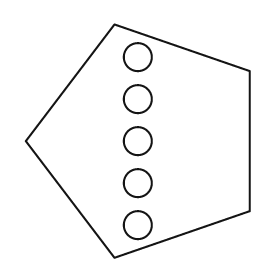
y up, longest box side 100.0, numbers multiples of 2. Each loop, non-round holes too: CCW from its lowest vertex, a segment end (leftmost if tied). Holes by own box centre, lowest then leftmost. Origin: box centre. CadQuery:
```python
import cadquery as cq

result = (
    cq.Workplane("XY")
    .moveTo(-10.0, -50.0)
    .lineTo(48.0, -30.0)
    .lineTo(48.0, 30.0)
    .lineTo(-10.0, 50.0)
    .lineTo(-48.0, 0.0)
    .close()
    .moveTo(0.0, -36.0)
    .circle(6.0)
    .moveTo(0.0, -18.0)
    .circle(6.0)
    .moveTo(0.0, 0.0)
    .circle(6.0)
    .moveTo(0.0, 18.0)
    .circle(6.0)
    .moveTo(0.0, 36.0)
    .circle(6.0)
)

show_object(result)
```